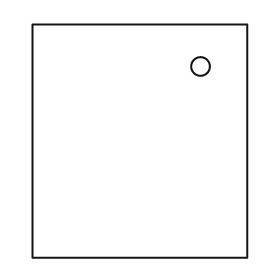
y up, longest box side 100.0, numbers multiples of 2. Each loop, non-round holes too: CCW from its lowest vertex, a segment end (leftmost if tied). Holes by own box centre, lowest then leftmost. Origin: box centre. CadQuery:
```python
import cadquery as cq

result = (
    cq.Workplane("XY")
    .moveTo(-46.0, -50.0)
    .lineTo(46.0, -50.0)
    .lineTo(46.0, 50.0)
    .lineTo(-46.0, 50.0)
    .close()
    .moveTo(26.0, 32.0)
    .circle(4.0)
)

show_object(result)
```